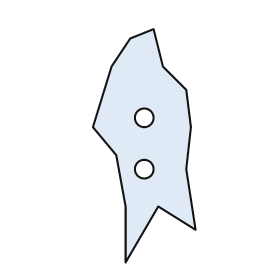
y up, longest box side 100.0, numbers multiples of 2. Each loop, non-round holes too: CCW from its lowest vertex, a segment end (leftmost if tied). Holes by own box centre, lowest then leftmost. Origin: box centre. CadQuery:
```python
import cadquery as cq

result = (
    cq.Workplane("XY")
    .moveTo(-8.0, -50.0)
    .lineTo(6.0, -26.0)
    .lineTo(22.0, -36.0)
    .lineTo(18.0, -10.0)
    .lineTo(20.0, 8.0)
    .lineTo(18.0, 24.0)
    .lineTo(8.0, 34.0)
    .lineTo(4.0, 50.0)
    .lineTo(-6.0, 46.0)
    .lineTo(-14.0, 34.0)
    .lineTo(-22.0, 8.0)
    .lineTo(-12.0, -4.0)
    .lineTo(-8.0, -26.0)
    .close()
    .moveTo(0.0, -10.0)
    .circle(4.0)
    .moveTo(0.0, 12.0)
    .circle(4.0)
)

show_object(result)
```